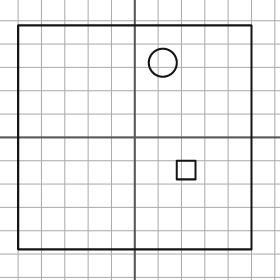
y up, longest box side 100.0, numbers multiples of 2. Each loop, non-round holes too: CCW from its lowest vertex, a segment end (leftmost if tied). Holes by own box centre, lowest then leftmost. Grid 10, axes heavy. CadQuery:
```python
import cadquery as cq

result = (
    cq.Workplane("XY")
    .moveTo(-50.0, -48.0)
    .lineTo(50.0, -48.0)
    .lineTo(50.0, 48.0)
    .lineTo(-50.0, 48.0)
    .close()
    .moveTo(18.0, -18.0)
    .lineTo(26.0, -18.0)
    .lineTo(26.0, -10.0)
    .lineTo(18.0, -10.0)
    .close()
    .moveTo(12.0, 32.0)
    .circle(6.0)
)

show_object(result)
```